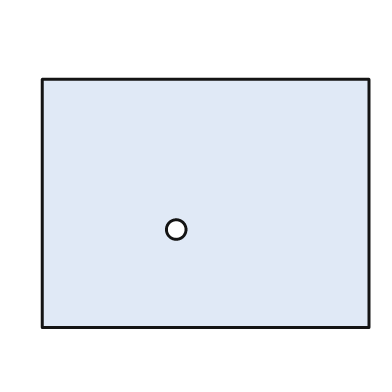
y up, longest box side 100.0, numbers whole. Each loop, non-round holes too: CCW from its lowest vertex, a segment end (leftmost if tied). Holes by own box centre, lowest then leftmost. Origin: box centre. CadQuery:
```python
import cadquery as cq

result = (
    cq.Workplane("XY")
    .moveTo(-50.0, -38.0)
    .lineTo(50.0, -38.0)
    .lineTo(50.0, 38.0)
    .lineTo(-50.0, 38.0)
    .close()
    .moveTo(-9.0, -8.0)
    .circle(3.0)
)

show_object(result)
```